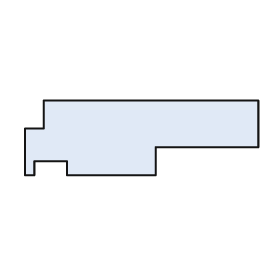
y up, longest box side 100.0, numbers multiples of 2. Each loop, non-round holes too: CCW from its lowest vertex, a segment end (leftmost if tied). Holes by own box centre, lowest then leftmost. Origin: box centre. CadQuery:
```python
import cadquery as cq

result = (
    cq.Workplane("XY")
    .moveTo(-50.0, -16.0)
    .lineTo(-46.0, -16.0)
    .lineTo(-46.0, -10.0)
    .lineTo(-32.0, -10.0)
    .lineTo(-32.0, -16.0)
    .lineTo(6.0, -16.0)
    .lineTo(6.0, -4.0)
    .lineTo(50.0, -4.0)
    .lineTo(50.0, 16.0)
    .lineTo(-42.0, 16.0)
    .lineTo(-42.0, 4.0)
    .lineTo(-50.0, 4.0)
    .close()
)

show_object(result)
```